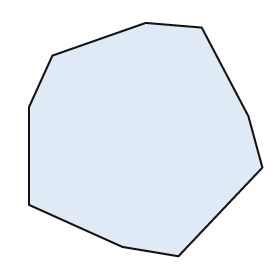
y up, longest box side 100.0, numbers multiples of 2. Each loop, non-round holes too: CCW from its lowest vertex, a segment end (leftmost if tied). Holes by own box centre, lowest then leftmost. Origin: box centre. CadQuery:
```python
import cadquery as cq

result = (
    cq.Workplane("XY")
    .moveTo(14.0, -50.0)
    .lineTo(50.0, -12.0)
    .lineTo(44.0, 10.0)
    .lineTo(24.0, 48.0)
    .lineTo(0.0, 50.0)
    .lineTo(-40.0, 36.0)
    .lineTo(-50.0, 14.0)
    .lineTo(-50.0, -28.0)
    .lineTo(-10.0, -46.0)
    .close()
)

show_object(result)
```